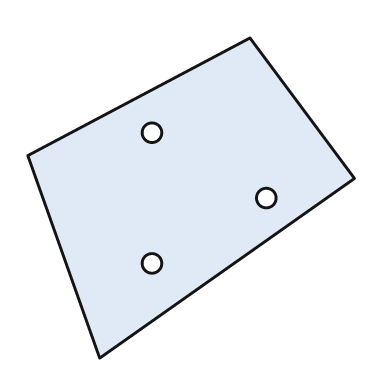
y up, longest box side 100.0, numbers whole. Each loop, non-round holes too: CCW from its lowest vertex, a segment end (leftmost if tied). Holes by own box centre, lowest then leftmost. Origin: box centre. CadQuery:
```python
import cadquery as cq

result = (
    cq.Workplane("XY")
    .moveTo(-28.0, -49.0)
    .lineTo(50.0, 6.0)
    .lineTo(18.0, 49.0)
    .lineTo(-50.0, 13.0)
    .close()
    .moveTo(-12.0, -20.0)
    .circle(3.0)
    .moveTo(23.0, 0.0)
    .circle(3.0)
    .moveTo(-12.0, 20.0)
    .circle(3.0)
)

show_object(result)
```